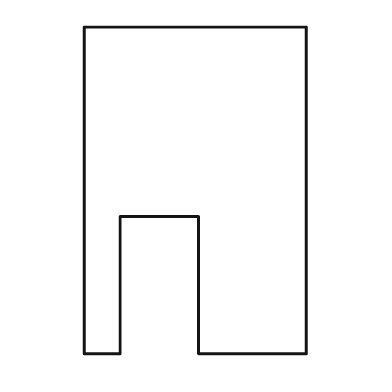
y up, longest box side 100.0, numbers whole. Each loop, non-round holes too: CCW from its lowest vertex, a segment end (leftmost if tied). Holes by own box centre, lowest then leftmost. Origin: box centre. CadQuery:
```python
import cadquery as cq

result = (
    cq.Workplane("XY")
    .moveTo(-34.0, -50.0)
    .lineTo(-23.0, -50.0)
    .lineTo(-23.0, -8.0)
    .lineTo(1.0, -8.0)
    .lineTo(1.0, -50.0)
    .lineTo(34.0, -50.0)
    .lineTo(34.0, 50.0)
    .lineTo(-34.0, 50.0)
    .close()
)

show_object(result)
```